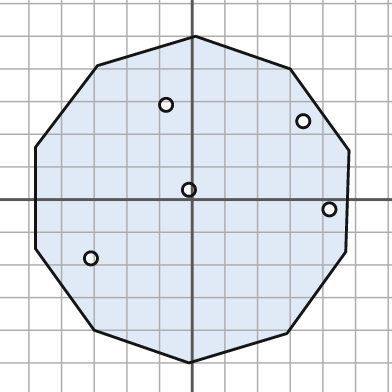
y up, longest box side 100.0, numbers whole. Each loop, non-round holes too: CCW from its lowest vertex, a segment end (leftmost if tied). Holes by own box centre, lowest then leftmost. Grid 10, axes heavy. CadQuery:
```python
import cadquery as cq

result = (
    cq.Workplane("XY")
    .moveTo(-1.0, -50.0)
    .lineTo(29.0, -41.0)
    .lineTo(47.0, -16.0)
    .lineTo(48.0, 15.0)
    .lineTo(30.0, 40.0)
    .lineTo(1.0, 50.0)
    .lineTo(-29.0, 41.0)
    .lineTo(-48.0, 16.0)
    .lineTo(-48.0, -15.0)
    .lineTo(-30.0, -40.0)
    .close()
    .moveTo(-31.0, -18.0)
    .circle(2.0)
    .moveTo(42.0, -3.0)
    .circle(2.0)
    .moveTo(-1.0, 3.0)
    .circle(2.0)
    .moveTo(34.0, 24.0)
    .circle(2.0)
    .moveTo(-8.0, 29.0)
    .circle(2.0)
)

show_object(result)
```